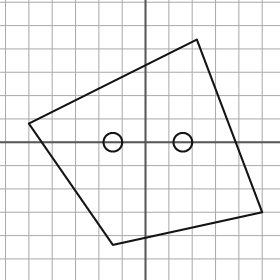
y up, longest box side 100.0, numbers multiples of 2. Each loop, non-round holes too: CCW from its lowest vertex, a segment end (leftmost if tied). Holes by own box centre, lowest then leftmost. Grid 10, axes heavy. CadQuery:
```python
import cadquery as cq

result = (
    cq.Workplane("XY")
    .moveTo(-14.0, -44.0)
    .lineTo(50.0, -30.0)
    .lineTo(22.0, 44.0)
    .lineTo(-50.0, 8.0)
    .close()
    .moveTo(-14.0, 0.0)
    .circle(4.0)
    .moveTo(16.0, 0.0)
    .circle(4.0)
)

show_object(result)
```